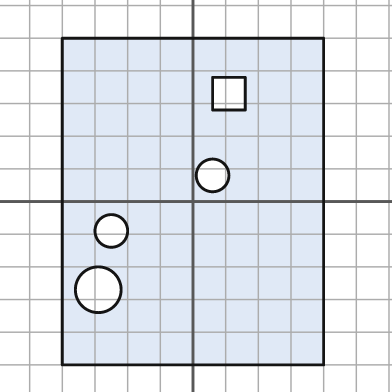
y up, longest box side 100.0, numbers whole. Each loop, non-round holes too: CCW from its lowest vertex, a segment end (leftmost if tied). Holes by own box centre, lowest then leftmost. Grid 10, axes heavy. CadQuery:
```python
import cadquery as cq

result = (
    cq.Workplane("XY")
    .moveTo(-40.0, -50.0)
    .lineTo(40.0, -50.0)
    .lineTo(40.0, 50.0)
    .lineTo(-40.0, 50.0)
    .close()
    .moveTo(-29.0, -27.0)
    .circle(7.0)
    .moveTo(-25.0, -9.0)
    .circle(5.0)
    .moveTo(6.0, 8.0)
    .circle(5.0)
    .moveTo(6.0, 28.0)
    .lineTo(16.0, 28.0)
    .lineTo(16.0, 38.0)
    .lineTo(6.0, 38.0)
    .close()
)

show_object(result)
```